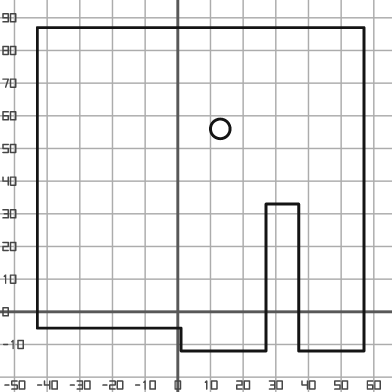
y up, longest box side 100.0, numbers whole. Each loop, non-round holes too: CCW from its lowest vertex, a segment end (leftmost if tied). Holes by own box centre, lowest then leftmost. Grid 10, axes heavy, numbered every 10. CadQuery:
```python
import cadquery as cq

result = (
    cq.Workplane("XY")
    .moveTo(1.0, -12.0)
    .lineTo(27.0, -12.0)
    .lineTo(27.0, 33.0)
    .lineTo(37.0, 33.0)
    .lineTo(37.0, -12.0)
    .lineTo(57.0, -12.0)
    .lineTo(57.0, 87.0)
    .lineTo(-43.0, 87.0)
    .lineTo(-43.0, -5.0)
    .lineTo(1.0, -5.0)
    .close()
    .moveTo(13.0, 56.0)
    .circle(3.0)
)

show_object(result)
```